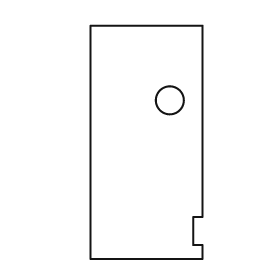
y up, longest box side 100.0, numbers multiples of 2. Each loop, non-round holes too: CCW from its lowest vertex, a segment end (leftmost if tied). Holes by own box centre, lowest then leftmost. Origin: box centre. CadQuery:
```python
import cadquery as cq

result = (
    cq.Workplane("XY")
    .moveTo(-24.0, -50.0)
    .lineTo(24.0, -50.0)
    .lineTo(24.0, -44.0)
    .lineTo(20.0, -44.0)
    .lineTo(20.0, -32.0)
    .lineTo(24.0, -32.0)
    .lineTo(24.0, 50.0)
    .lineTo(-24.0, 50.0)
    .close()
    .moveTo(10.0, 18.0)
    .circle(6.0)
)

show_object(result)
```